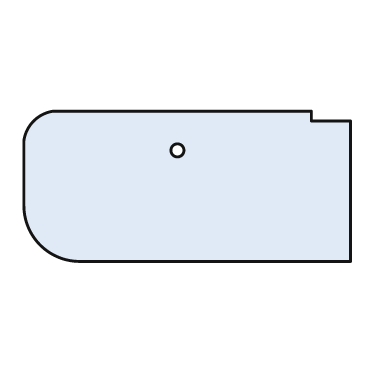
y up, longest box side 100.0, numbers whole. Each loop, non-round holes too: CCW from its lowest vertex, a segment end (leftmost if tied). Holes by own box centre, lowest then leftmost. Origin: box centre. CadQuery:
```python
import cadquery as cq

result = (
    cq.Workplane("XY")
    .moveTo(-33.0, -23.0)
    .lineTo(50.0, -23.0)
    .lineTo(50.0, 20.0)
    .lineTo(38.0, 20.0)
    .lineTo(38.0, 23.0)
    .lineTo(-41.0, 23.0)
    .threePointArc((-47.0, 20.0), (-50.0, 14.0))
    .lineTo(-50.0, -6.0)
    .threePointArc((-45.0, -18.0), (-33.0, -23.0))
    .close()
    .moveTo(-3.0, 11.0)
    .circle(2.0)
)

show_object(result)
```